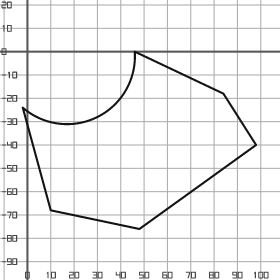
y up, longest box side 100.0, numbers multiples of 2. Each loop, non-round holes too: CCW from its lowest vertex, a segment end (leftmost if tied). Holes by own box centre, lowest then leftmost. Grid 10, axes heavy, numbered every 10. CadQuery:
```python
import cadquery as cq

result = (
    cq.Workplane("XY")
    .moveTo(48.0, -76.0)
    .lineTo(98.0, -40.0)
    .lineTo(84.0, -18.0)
    .lineTo(46.0, 0.0)
    .threePointArc((30.0, -28.0), (-2.0, -24.0))
    .lineTo(10.0, -68.0)
    .close()
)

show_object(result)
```